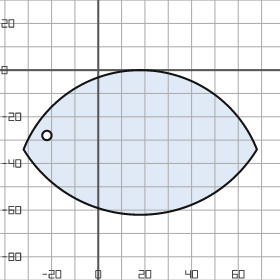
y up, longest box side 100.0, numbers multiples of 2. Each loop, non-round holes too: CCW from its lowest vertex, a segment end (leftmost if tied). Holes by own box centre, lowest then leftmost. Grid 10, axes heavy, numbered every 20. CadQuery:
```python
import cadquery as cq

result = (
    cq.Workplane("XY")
    .moveTo(-32.0, -34.0)
    .threePointArc((18.0, -62.0), (68.0, -34.0))
    .threePointArc((18.0, 0.0), (-32.0, -34.0))
    .close()
    .moveTo(-22.0, -28.0)
    .circle(2.0)
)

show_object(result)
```